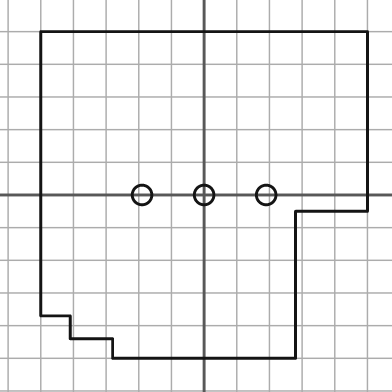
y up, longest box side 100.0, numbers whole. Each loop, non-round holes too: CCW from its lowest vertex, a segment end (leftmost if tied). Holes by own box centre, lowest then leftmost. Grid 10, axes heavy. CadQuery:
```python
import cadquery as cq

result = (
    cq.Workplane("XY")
    .moveTo(-28.0, -50.0)
    .lineTo(28.0, -50.0)
    .lineTo(28.0, -5.0)
    .lineTo(50.0, -5.0)
    .lineTo(50.0, 50.0)
    .lineTo(-50.0, 50.0)
    .lineTo(-50.0, -37.0)
    .lineTo(-41.0, -37.0)
    .lineTo(-41.0, -44.0)
    .lineTo(-28.0, -44.0)
    .close()
    .moveTo(-19.0, 0.0)
    .circle(3.0)
    .moveTo(0.0, 0.0)
    .circle(3.0)
    .moveTo(19.0, 0.0)
    .circle(3.0)
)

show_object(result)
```